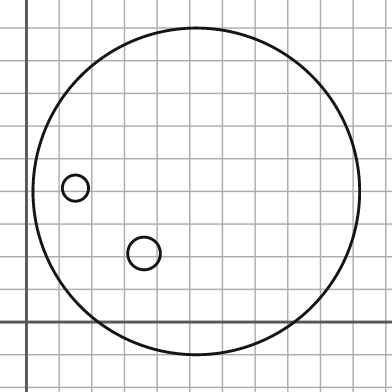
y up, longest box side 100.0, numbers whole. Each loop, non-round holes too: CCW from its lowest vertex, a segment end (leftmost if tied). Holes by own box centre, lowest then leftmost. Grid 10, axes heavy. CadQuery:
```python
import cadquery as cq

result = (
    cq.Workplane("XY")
    .moveTo(52.0, 40.0)
    .circle(50.0)
    .moveTo(36.0, 21.0)
    .circle(5.0)
    .moveTo(15.0, 41.0)
    .circle(4.0)
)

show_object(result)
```